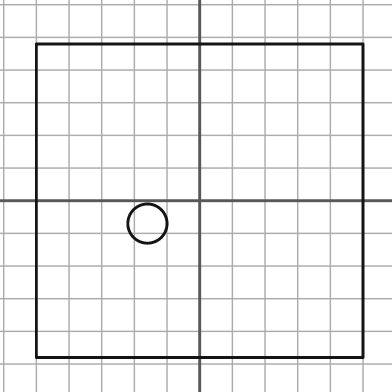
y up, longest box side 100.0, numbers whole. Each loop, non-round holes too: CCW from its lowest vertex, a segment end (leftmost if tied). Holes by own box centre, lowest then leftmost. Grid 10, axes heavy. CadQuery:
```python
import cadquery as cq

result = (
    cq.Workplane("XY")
    .moveTo(-50.0, -48.0)
    .lineTo(50.0, -48.0)
    .lineTo(50.0, 48.0)
    .lineTo(-50.0, 48.0)
    .close()
    .moveTo(-16.0, -7.0)
    .circle(6.0)
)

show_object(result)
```